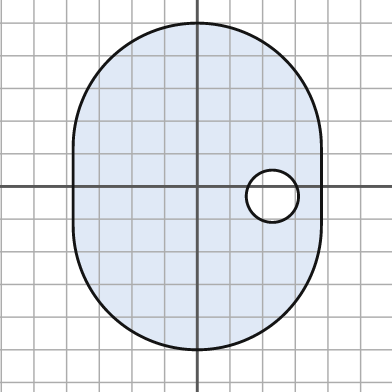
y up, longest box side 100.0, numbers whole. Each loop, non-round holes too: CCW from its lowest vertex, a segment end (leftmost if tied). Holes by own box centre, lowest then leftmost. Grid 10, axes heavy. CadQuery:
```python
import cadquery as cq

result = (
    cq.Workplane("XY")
    .moveTo(-38.0, -12.0)
    .threePointArc((0.0, -50.0), (38.0, -12.0))
    .lineTo(38.0, 12.0)
    .threePointArc((0.0, 50.0), (-38.0, 12.0))
    .close()
    .moveTo(23.0, -3.0)
    .circle(8.0)
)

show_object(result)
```